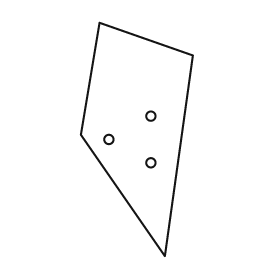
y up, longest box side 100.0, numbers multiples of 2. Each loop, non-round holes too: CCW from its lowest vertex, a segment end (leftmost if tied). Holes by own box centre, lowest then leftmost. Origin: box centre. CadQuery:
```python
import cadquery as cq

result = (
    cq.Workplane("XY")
    .moveTo(12.0, -50.0)
    .lineTo(24.0, 36.0)
    .lineTo(-16.0, 50.0)
    .lineTo(-24.0, 2.0)
    .close()
    .moveTo(6.0, -10.0)
    .circle(2.0)
    .moveTo(-12.0, 0.0)
    .circle(2.0)
    .moveTo(6.0, 10.0)
    .circle(2.0)
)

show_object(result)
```